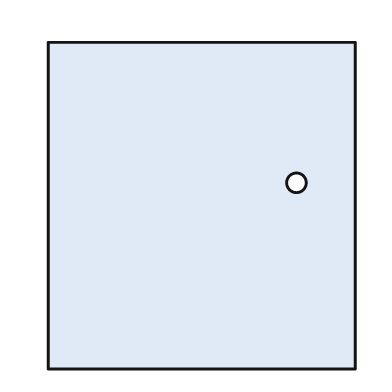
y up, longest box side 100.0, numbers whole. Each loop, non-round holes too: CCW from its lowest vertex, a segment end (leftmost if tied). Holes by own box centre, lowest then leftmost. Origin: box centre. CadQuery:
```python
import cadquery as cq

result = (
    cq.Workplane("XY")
    .moveTo(-47.0, -50.0)
    .lineTo(47.0, -50.0)
    .lineTo(47.0, 50.0)
    .lineTo(-47.0, 50.0)
    .close()
    .moveTo(29.0, 7.0)
    .circle(3.0)
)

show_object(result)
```